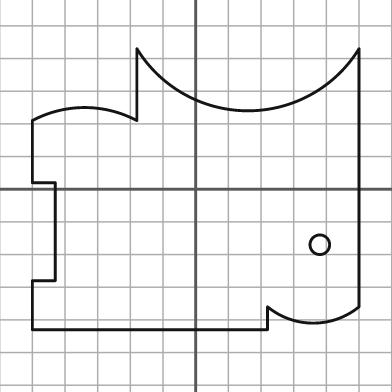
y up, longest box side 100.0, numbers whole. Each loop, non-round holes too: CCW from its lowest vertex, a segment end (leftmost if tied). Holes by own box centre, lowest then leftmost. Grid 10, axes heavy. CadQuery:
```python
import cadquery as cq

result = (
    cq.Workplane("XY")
    .moveTo(-50.0, -43.0)
    .lineTo(22.0, -43.0)
    .lineTo(22.0, -36.0)
    .threePointArc((36.0, -41.0), (50.0, -36.0))
    .lineTo(50.0, 43.0)
    .threePointArc((16.0, 24.0), (-18.0, 43.0))
    .lineTo(-18.0, 21.0)
    .threePointArc((-34.0, 25.0), (-50.0, 21.0))
    .lineTo(-50.0, 2.0)
    .lineTo(-43.0, 2.0)
    .lineTo(-43.0, -28.0)
    .lineTo(-50.0, -28.0)
    .close()
    .moveTo(38.0, -17.0)
    .circle(3.0)
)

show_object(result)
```